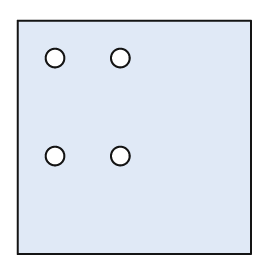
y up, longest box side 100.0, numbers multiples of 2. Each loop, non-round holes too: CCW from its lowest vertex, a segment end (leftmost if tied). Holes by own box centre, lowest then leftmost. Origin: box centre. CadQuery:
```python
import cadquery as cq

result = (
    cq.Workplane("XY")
    .moveTo(-50.0, -50.0)
    .lineTo(50.0, -50.0)
    .lineTo(50.0, 50.0)
    .lineTo(-50.0, 50.0)
    .close()
    .moveTo(-34.0, -8.0)
    .circle(4.0)
    .moveTo(-6.0, -8.0)
    .circle(4.0)
    .moveTo(-34.0, 34.0)
    .circle(4.0)
    .moveTo(-6.0, 34.0)
    .circle(4.0)
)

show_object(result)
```